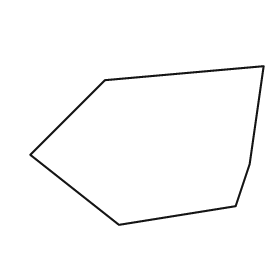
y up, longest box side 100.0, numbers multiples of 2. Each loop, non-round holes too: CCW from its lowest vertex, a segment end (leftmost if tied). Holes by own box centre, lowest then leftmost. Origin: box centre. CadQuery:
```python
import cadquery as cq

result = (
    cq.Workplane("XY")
    .moveTo(-12.0, -34.0)
    .lineTo(38.0, -26.0)
    .lineTo(44.0, -8.0)
    .lineTo(50.0, 34.0)
    .lineTo(-18.0, 28.0)
    .lineTo(-50.0, -4.0)
    .close()
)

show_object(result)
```